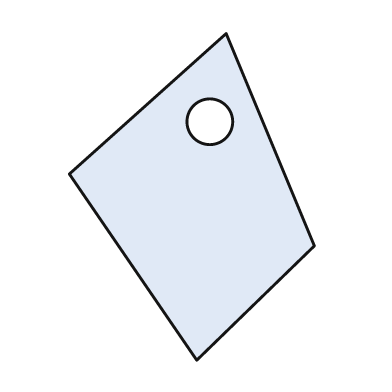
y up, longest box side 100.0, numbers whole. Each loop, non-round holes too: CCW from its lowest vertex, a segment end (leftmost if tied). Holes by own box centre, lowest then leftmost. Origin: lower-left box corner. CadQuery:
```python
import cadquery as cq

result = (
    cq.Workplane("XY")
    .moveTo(39.0, 0.0)
    .lineTo(75.0, 35.0)
    .lineTo(48.0, 100.0)
    .lineTo(0.0, 57.0)
    .close()
    .moveTo(43.0, 73.0)
    .circle(7.0)
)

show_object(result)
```